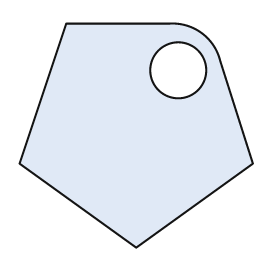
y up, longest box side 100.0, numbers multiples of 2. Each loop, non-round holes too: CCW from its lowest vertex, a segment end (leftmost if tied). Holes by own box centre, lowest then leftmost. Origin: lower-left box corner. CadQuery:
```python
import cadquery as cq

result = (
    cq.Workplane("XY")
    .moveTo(50.0, 0.0)
    .lineTo(100.0, 36.0)
    .lineTo(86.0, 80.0)
    .threePointArc((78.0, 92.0), (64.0, 96.0))
    .lineTo(20.0, 96.0)
    .lineTo(0.0, 36.0)
    .close()
    .moveTo(68.0, 76.0)
    .circle(12.0)
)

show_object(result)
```